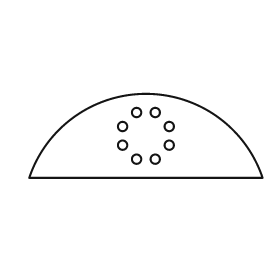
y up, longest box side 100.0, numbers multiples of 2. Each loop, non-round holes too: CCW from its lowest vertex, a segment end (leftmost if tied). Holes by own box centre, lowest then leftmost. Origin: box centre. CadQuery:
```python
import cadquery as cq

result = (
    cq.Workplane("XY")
    .moveTo(-50.0, -18.0)
    .lineTo(50.0, -18.0)
    .threePointArc((0.0, 18.0), (-50.0, -18.0))
    .close()
    .moveTo(-4.0, -10.0)
    .circle(2.0)
    .moveTo(4.0, -10.0)
    .circle(2.0)
    .moveTo(-10.0, -4.0)
    .circle(2.0)
    .moveTo(10.0, -4.0)
    .circle(2.0)
    .moveTo(-10.0, 4.0)
    .circle(2.0)
    .moveTo(10.0, 4.0)
    .circle(2.0)
    .moveTo(-4.0, 10.0)
    .circle(2.0)
    .moveTo(4.0, 10.0)
    .circle(2.0)
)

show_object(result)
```